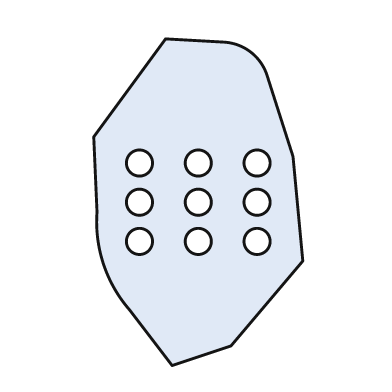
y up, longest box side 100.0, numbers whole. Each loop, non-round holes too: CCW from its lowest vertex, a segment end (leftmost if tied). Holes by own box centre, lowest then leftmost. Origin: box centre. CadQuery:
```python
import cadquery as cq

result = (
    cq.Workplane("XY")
    .moveTo(-8.0, -50.0)
    .lineTo(10.0, -44.0)
    .lineTo(32.0, -18.0)
    .lineTo(29.0, 14.0)
    .lineTo(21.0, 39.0)
    .threePointArc((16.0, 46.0), (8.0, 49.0))
    .lineTo(-10.0, 50.0)
    .lineTo(-32.0, 20.0)
    .lineTo(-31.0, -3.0)
    .threePointArc((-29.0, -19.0), (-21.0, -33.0))
    .close()
    .moveTo(-18.0, -12.0)
    .circle(4.0)
    .moveTo(0.0, -12.0)
    .circle(4.0)
    .moveTo(18.0, -12.0)
    .circle(4.0)
    .moveTo(-18.0, 0.0)
    .circle(4.0)
    .moveTo(0.0, 0.0)
    .circle(4.0)
    .moveTo(18.0, 0.0)
    .circle(4.0)
    .moveTo(-18.0, 12.0)
    .circle(4.0)
    .moveTo(0.0, 12.0)
    .circle(4.0)
    .moveTo(18.0, 12.0)
    .circle(4.0)
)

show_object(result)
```